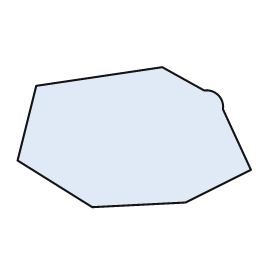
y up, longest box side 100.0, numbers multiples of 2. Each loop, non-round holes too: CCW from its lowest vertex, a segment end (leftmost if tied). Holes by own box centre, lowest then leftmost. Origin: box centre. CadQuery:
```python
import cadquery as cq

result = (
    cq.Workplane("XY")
    .moveTo(-18.0, -30.0)
    .lineTo(22.0, -28.0)
    .lineTo(50.0, -14.0)
    .lineTo(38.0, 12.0)
    .threePointArc((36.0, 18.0), (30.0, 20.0))
    .lineTo(12.0, 30.0)
    .lineTo(-42.0, 22.0)
    .lineTo(-50.0, -10.0)
    .close()
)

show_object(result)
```